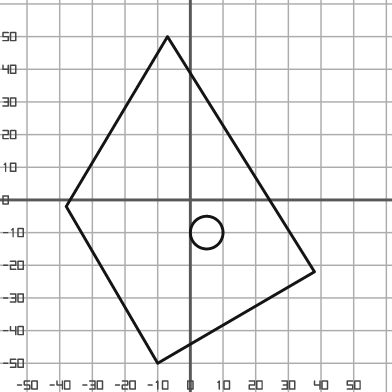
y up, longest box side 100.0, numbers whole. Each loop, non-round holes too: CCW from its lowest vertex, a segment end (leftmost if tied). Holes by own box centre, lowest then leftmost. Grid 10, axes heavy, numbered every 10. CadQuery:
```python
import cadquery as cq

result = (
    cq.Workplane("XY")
    .moveTo(-10.0, -50.0)
    .lineTo(38.0, -22.0)
    .lineTo(-7.0, 50.0)
    .lineTo(-38.0, -2.0)
    .close()
    .moveTo(5.0, -10.0)
    .circle(5.0)
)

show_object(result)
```